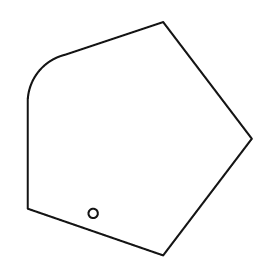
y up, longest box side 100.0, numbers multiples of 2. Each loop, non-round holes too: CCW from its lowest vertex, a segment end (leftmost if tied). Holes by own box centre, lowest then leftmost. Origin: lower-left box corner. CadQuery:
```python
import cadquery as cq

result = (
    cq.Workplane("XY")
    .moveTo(58.0, 0.0)
    .lineTo(96.0, 50.0)
    .lineTo(58.0, 100.0)
    .lineTo(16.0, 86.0)
    .threePointArc((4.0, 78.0), (0.0, 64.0))
    .lineTo(0.0, 20.0)
    .close()
    .moveTo(28.0, 18.0)
    .circle(2.0)
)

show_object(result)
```